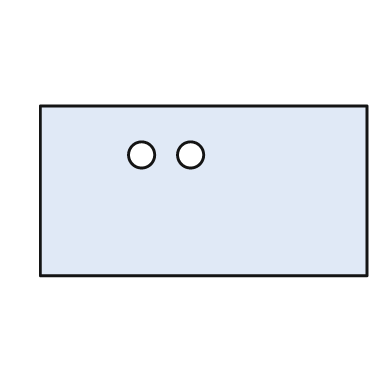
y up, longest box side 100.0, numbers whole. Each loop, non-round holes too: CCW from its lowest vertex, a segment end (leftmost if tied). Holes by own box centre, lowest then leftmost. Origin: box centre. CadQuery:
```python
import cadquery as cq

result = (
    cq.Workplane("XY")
    .moveTo(-50.0, -26.0)
    .lineTo(50.0, -26.0)
    .lineTo(50.0, 26.0)
    .lineTo(-50.0, 26.0)
    .close()
    .moveTo(-19.0, 11.0)
    .circle(4.0)
    .moveTo(-4.0, 11.0)
    .circle(4.0)
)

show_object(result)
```